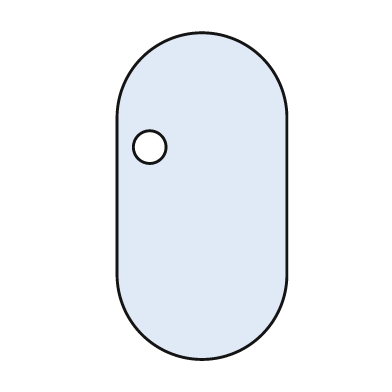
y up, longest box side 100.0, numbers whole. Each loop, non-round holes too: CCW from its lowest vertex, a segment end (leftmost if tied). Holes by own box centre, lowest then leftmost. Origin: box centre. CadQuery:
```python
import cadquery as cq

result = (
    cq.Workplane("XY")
    .moveTo(-26.0, -24.0)
    .threePointArc((0.0, -50.0), (26.0, -24.0))
    .lineTo(26.0, 24.0)
    .threePointArc((0.0, 50.0), (-26.0, 24.0))
    .close()
    .moveTo(-16.0, 15.0)
    .circle(5.0)
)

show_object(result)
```